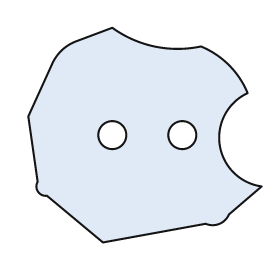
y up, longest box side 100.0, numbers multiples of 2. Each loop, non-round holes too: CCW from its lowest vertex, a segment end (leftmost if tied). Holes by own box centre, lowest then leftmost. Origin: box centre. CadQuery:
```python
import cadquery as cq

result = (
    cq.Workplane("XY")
    .moveTo(-18.0, -46.0)
    .lineTo(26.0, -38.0)
    .threePointArc((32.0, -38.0), (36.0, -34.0))
    .lineTo(50.0, -22.0)
    .threePointArc((32.0, -4.0), (44.0, 18.0))
    .threePointArc((36.0, 30.0), (24.0, 38.0))
    .threePointArc((4.0, 38.0), (-14.0, 46.0))
    .lineTo(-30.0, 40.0)
    .threePointArc((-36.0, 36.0), (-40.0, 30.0))
    .lineTo(-50.0, 8.0)
    .lineTo(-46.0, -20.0)
    .threePointArc((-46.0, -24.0), (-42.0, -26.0))
    .close()
    .moveTo(-14.0, 0.0)
    .circle(6.0)
    .moveTo(16.0, 0.0)
    .circle(6.0)
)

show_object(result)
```